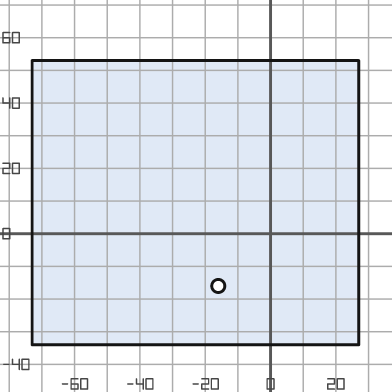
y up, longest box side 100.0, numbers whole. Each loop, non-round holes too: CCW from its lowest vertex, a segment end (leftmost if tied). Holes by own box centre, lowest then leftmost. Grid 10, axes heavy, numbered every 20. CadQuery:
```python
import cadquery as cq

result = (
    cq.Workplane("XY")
    .moveTo(-73.0, -34.0)
    .lineTo(27.0, -34.0)
    .lineTo(27.0, 53.0)
    .lineTo(-73.0, 53.0)
    .close()
    .moveTo(-16.0, -16.0)
    .circle(2.0)
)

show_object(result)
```